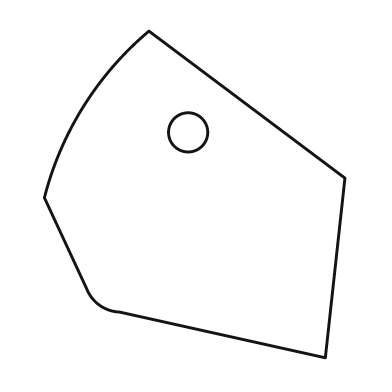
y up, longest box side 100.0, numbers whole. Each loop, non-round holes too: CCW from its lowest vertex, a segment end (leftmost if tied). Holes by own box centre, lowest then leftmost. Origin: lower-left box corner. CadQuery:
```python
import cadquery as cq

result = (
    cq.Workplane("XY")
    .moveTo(86.0, 0.0)
    .lineTo(92.0, 55.0)
    .lineTo(32.0, 100.0)
    .threePointArc((12.0, 77.0), (0.0, 49.0))
    .lineTo(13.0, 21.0)
    .threePointArc((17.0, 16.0), (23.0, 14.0))
    .close()
    .moveTo(44.0, 69.0)
    .circle(6.0)
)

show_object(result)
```